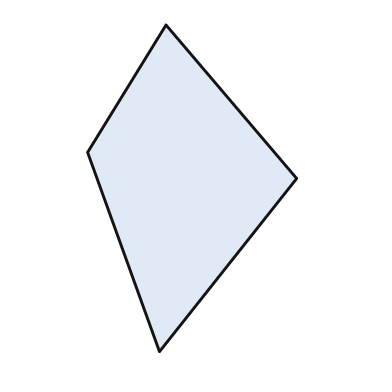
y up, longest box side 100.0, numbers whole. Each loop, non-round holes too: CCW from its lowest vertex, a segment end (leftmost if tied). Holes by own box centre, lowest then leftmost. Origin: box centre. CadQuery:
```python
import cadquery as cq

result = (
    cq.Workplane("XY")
    .moveTo(-10.0, -50.0)
    .lineTo(32.0, 3.0)
    .lineTo(-8.0, 50.0)
    .lineTo(-32.0, 11.0)
    .close()
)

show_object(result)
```